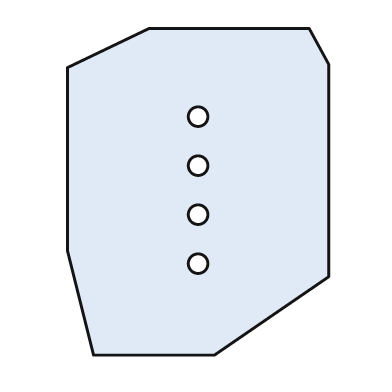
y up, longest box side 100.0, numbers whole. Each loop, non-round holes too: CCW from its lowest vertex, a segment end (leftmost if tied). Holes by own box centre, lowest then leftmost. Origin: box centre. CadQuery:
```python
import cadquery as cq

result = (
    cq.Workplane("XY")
    .moveTo(-32.0, -50.0)
    .lineTo(5.0, -50.0)
    .lineTo(40.0, -26.0)
    .lineTo(40.0, 39.0)
    .lineTo(34.0, 50.0)
    .lineTo(-15.0, 50.0)
    .lineTo(-40.0, 38.0)
    .lineTo(-40.0, -18.0)
    .close()
    .moveTo(0.0, -22.0)
    .circle(3.0)
    .moveTo(0.0, -7.0)
    .circle(3.0)
    .moveTo(0.0, 8.0)
    .circle(3.0)
    .moveTo(0.0, 23.0)
    .circle(3.0)
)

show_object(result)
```